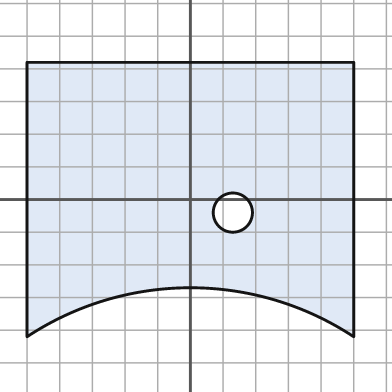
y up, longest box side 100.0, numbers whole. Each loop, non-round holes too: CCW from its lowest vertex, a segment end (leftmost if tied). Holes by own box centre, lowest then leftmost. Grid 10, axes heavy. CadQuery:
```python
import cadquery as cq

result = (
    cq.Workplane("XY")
    .moveTo(-50.0, -42.0)
    .threePointArc((0.0, -27.0), (50.0, -42.0))
    .lineTo(50.0, 42.0)
    .lineTo(-50.0, 42.0)
    .close()
    .moveTo(13.0, -4.0)
    .circle(6.0)
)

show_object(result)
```